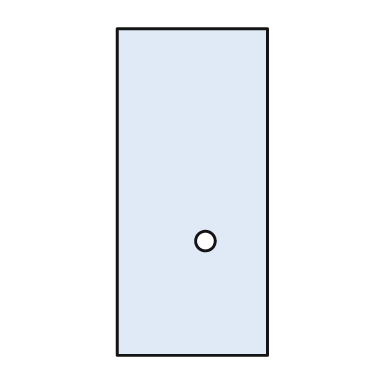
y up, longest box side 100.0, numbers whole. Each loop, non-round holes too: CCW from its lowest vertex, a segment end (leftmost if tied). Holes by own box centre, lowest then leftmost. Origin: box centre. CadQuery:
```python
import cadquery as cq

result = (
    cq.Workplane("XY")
    .moveTo(-23.0, -50.0)
    .lineTo(23.0, -50.0)
    .lineTo(23.0, 50.0)
    .lineTo(-23.0, 50.0)
    .close()
    .moveTo(4.0, -15.0)
    .circle(3.0)
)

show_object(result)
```